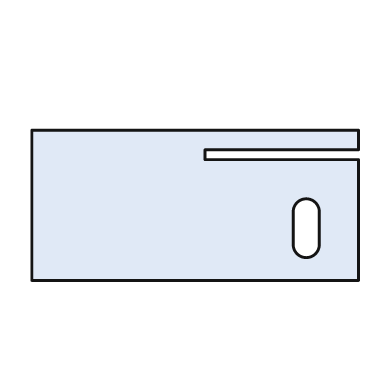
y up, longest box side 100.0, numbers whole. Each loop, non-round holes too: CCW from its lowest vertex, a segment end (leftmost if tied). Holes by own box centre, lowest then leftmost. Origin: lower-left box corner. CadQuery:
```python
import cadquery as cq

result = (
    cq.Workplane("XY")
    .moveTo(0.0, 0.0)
    .lineTo(100.0, 0.0)
    .lineTo(100.0, 37.0)
    .lineTo(53.0, 37.0)
    .lineTo(53.0, 40.0)
    .lineTo(100.0, 40.0)
    .lineTo(100.0, 46.0)
    .lineTo(0.0, 46.0)
    .close()
    .moveTo(80.0, 11.0)
    .threePointArc((84.0, 7.0), (88.0, 11.0))
    .lineTo(88.0, 21.0)
    .threePointArc((84.0, 25.0), (80.0, 21.0))
    .close()
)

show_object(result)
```